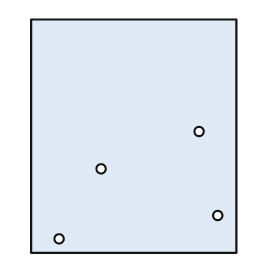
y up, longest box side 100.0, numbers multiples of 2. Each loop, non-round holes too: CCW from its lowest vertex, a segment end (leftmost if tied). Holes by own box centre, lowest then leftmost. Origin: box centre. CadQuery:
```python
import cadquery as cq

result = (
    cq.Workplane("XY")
    .moveTo(-44.0, -50.0)
    .lineTo(44.0, -50.0)
    .lineTo(44.0, 50.0)
    .lineTo(-44.0, 50.0)
    .close()
    .moveTo(-32.0, -44.0)
    .circle(2.0)
    .moveTo(36.0, -34.0)
    .circle(2.0)
    .moveTo(-14.0, -14.0)
    .circle(2.0)
    .moveTo(28.0, 2.0)
    .circle(2.0)
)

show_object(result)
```